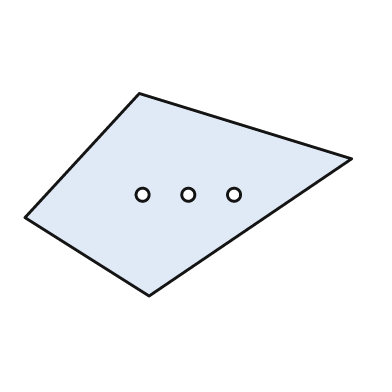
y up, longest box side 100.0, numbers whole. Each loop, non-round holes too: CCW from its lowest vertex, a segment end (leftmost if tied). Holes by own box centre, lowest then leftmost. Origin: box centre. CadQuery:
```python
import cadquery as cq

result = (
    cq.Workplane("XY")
    .moveTo(-12.0, -31.0)
    .lineTo(50.0, 11.0)
    .lineTo(-15.0, 31.0)
    .lineTo(-50.0, -7.0)
    .close()
    .moveTo(-14.0, 0.0)
    .circle(2.0)
    .moveTo(0.0, 0.0)
    .circle(2.0)
    .moveTo(14.0, 0.0)
    .circle(2.0)
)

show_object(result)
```